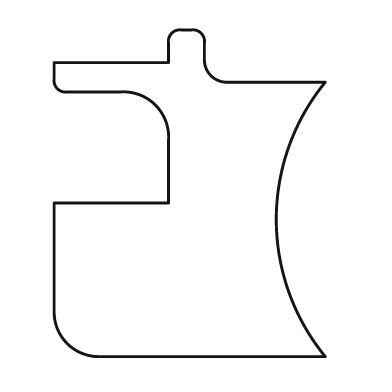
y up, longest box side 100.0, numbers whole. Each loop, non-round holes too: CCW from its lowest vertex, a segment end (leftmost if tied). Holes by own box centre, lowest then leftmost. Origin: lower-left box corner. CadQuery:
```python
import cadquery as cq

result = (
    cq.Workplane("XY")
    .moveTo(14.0, 0.0)
    .lineTo(83.0, 0.0)
    .threePointArc((68.0, 42.0), (83.0, 84.0))
    .lineTo(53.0, 84.0)
    .threePointArc((48.0, 86.0), (46.0, 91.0))
    .lineTo(46.0, 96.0)
    .threePointArc((45.0, 99.0), (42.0, 100.0))
    .lineTo(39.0, 100.0)
    .threePointArc((36.0, 99.0), (35.0, 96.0))
    .lineTo(35.0, 90.0)
    .lineTo(0.0, 90.0)
    .lineTo(0.0, 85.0)
    .threePointArc((1.0, 82.0), (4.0, 81.0))
    .lineTo(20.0, 81.0)
    .threePointArc((31.0, 77.0), (35.0, 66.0))
    .lineTo(35.0, 47.0)
    .lineTo(0.0, 47.0)
    .lineTo(0.0, 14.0)
    .threePointArc((4.0, 4.0), (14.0, 0.0))
    .close()
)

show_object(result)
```